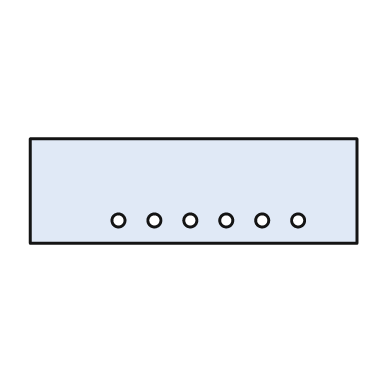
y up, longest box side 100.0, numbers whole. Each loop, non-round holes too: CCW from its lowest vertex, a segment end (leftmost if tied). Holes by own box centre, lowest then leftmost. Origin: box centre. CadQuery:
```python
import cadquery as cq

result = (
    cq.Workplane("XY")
    .moveTo(-50.0, -16.0)
    .lineTo(50.0, -16.0)
    .lineTo(50.0, 16.0)
    .lineTo(-50.0, 16.0)
    .close()
    .moveTo(-23.0, -9.0)
    .circle(2.0)
    .moveTo(-12.0, -9.0)
    .circle(2.0)
    .moveTo(-1.0, -9.0)
    .circle(2.0)
    .moveTo(10.0, -9.0)
    .circle(2.0)
    .moveTo(21.0, -9.0)
    .circle(2.0)
    .moveTo(32.0, -9.0)
    .circle(2.0)
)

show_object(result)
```